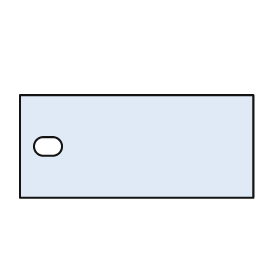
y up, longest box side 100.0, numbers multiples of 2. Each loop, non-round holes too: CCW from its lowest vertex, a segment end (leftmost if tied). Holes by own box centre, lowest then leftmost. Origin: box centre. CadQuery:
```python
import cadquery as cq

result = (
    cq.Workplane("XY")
    .moveTo(-50.0, -22.0)
    .lineTo(50.0, -22.0)
    .lineTo(50.0, 22.0)
    .lineTo(-50.0, 22.0)
    .close()
    .moveTo(-40.0, -4.0)
    .lineTo(-36.0, -4.0)
    .threePointArc((-32.0, 0.0), (-36.0, 4.0))
    .lineTo(-40.0, 4.0)
    .threePointArc((-44.0, 0.0), (-40.0, -4.0))
    .close()
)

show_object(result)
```